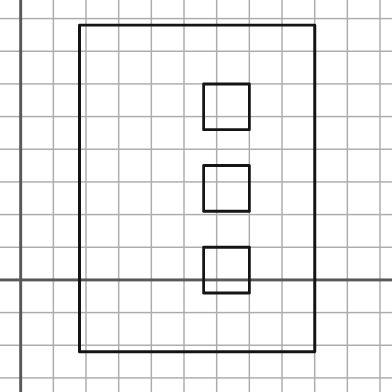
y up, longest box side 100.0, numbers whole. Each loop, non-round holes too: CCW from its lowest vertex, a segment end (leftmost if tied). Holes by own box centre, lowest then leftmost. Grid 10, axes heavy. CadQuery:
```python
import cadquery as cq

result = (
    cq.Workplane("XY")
    .moveTo(18.0, -22.0)
    .lineTo(90.0, -22.0)
    .lineTo(90.0, 78.0)
    .lineTo(18.0, 78.0)
    .close()
    .moveTo(56.0, -4.0)
    .lineTo(70.0, -4.0)
    .lineTo(70.0, 10.0)
    .lineTo(56.0, 10.0)
    .close()
    .moveTo(56.0, 21.0)
    .lineTo(70.0, 21.0)
    .lineTo(70.0, 35.0)
    .lineTo(56.0, 35.0)
    .close()
    .moveTo(56.0, 46.0)
    .lineTo(70.0, 46.0)
    .lineTo(70.0, 60.0)
    .lineTo(56.0, 60.0)
    .close()
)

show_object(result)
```